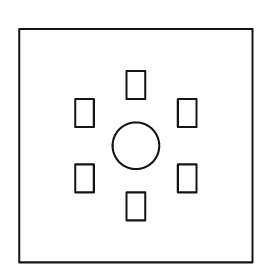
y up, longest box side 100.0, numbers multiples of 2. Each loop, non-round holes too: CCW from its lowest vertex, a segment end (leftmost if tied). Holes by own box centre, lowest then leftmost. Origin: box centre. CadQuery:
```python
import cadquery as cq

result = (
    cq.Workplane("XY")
    .moveTo(-50.0, -50.0)
    .lineTo(50.0, -50.0)
    .lineTo(50.0, 50.0)
    .lineTo(-50.0, 50.0)
    .close()
    .moveTo(-4.0, -32.0)
    .lineTo(4.0, -32.0)
    .lineTo(4.0, -20.0)
    .lineTo(-4.0, -20.0)
    .close()
    .moveTo(-26.0, -20.0)
    .lineTo(-18.0, -20.0)
    .lineTo(-18.0, -8.0)
    .lineTo(-26.0, -8.0)
    .close()
    .moveTo(18.0, -20.0)
    .lineTo(26.0, -20.0)
    .lineTo(26.0, -8.0)
    .lineTo(18.0, -8.0)
    .close()
    .moveTo(0.0, 0.0)
    .circle(10.0)
    .moveTo(-26.0, 8.0)
    .lineTo(-18.0, 8.0)
    .lineTo(-18.0, 20.0)
    .lineTo(-26.0, 20.0)
    .close()
    .moveTo(18.0, 8.0)
    .lineTo(26.0, 8.0)
    .lineTo(26.0, 20.0)
    .lineTo(18.0, 20.0)
    .close()
    .moveTo(-4.0, 20.0)
    .lineTo(4.0, 20.0)
    .lineTo(4.0, 32.0)
    .lineTo(-4.0, 32.0)
    .close()
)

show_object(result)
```